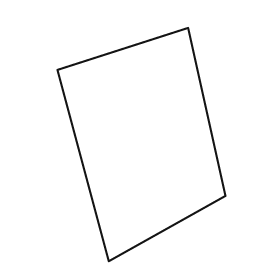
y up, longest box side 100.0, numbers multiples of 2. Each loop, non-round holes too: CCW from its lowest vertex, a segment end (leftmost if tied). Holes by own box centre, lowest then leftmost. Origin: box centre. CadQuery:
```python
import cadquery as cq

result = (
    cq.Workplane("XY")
    .moveTo(-14.0, -50.0)
    .lineTo(36.0, -22.0)
    .lineTo(20.0, 50.0)
    .lineTo(-36.0, 32.0)
    .close()
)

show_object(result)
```